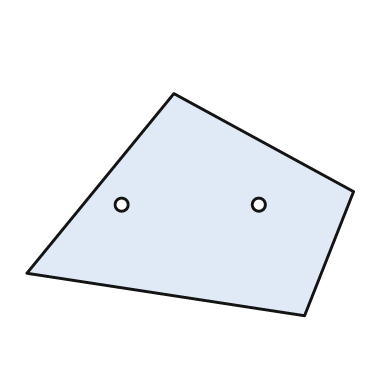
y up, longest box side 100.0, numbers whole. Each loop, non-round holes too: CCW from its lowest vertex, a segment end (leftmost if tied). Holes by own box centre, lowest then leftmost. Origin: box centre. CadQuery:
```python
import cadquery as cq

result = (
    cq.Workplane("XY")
    .moveTo(35.0, -34.0)
    .lineTo(50.0, 4.0)
    .lineTo(-5.0, 34.0)
    .lineTo(-50.0, -21.0)
    .close()
    .moveTo(-21.0, 0.0)
    .circle(2.0)
    .moveTo(21.0, 0.0)
    .circle(2.0)
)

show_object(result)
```